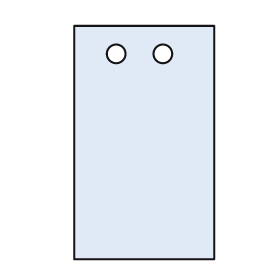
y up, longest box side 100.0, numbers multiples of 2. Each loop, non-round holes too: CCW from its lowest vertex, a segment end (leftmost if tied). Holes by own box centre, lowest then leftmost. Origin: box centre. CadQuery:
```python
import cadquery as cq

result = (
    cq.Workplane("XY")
    .moveTo(-30.0, -50.0)
    .lineTo(30.0, -50.0)
    .lineTo(30.0, 50.0)
    .lineTo(-30.0, 50.0)
    .close()
    .moveTo(-12.0, 38.0)
    .circle(4.0)
    .moveTo(8.0, 38.0)
    .circle(4.0)
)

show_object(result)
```